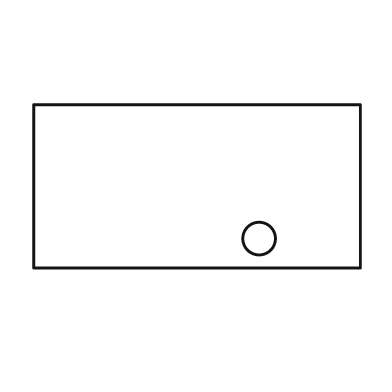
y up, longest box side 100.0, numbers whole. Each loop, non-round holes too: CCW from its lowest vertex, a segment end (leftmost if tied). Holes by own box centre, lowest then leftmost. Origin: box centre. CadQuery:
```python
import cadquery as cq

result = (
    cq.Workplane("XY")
    .moveTo(-50.0, -25.0)
    .lineTo(50.0, -25.0)
    .lineTo(50.0, 25.0)
    .lineTo(-50.0, 25.0)
    .close()
    .moveTo(19.0, -16.0)
    .circle(5.0)
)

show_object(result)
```